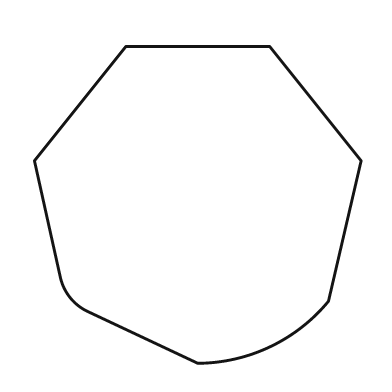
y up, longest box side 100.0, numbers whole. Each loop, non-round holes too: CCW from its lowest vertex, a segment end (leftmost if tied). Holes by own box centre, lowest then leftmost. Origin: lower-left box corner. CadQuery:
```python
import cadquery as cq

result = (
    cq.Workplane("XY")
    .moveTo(50.0, 0.0)
    .threePointArc((72.0, 5.0), (90.0, 19.0))
    .lineTo(100.0, 62.0)
    .lineTo(72.0, 97.0)
    .lineTo(28.0, 97.0)
    .lineTo(0.0, 62.0)
    .lineTo(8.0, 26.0)
    .threePointArc((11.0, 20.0), (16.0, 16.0))
    .close()
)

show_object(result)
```